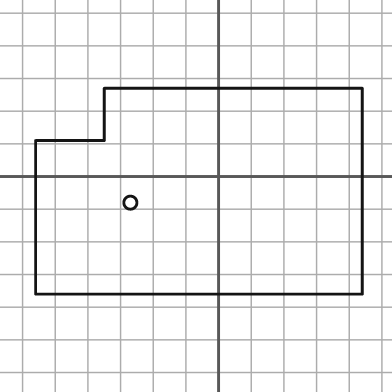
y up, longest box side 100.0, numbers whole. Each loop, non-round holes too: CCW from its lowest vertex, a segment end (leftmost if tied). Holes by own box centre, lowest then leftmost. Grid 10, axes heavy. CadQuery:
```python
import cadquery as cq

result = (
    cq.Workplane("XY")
    .moveTo(-56.0, -36.0)
    .lineTo(44.0, -36.0)
    .lineTo(44.0, 27.0)
    .lineTo(-35.0, 27.0)
    .lineTo(-35.0, 11.0)
    .lineTo(-56.0, 11.0)
    .close()
    .moveTo(-27.0, -8.0)
    .circle(2.0)
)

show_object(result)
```